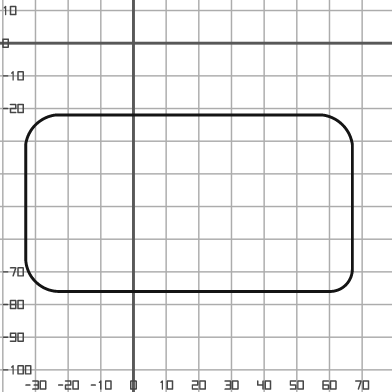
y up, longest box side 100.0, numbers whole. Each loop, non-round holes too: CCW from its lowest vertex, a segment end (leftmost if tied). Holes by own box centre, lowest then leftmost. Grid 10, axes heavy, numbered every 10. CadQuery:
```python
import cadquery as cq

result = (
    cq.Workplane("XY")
    .moveTo(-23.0, -76.0)
    .lineTo(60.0, -76.0)
    .threePointArc((65.0, -74.0), (67.0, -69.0))
    .lineTo(67.0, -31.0)
    .threePointArc((64.0, -25.0), (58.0, -22.0))
    .lineTo(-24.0, -22.0)
    .threePointArc((-30.0, -25.0), (-33.0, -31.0))
    .lineTo(-33.0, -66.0)
    .threePointArc((-30.0, -73.0), (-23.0, -76.0))
    .close()
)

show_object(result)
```